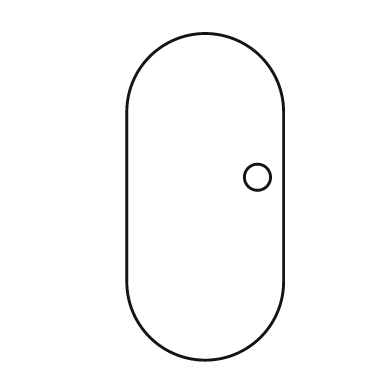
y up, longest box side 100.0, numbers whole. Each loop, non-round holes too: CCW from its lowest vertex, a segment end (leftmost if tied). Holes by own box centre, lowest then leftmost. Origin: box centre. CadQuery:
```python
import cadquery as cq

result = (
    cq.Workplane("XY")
    .moveTo(-24.0, -26.0)
    .threePointArc((0.0, -50.0), (24.0, -26.0))
    .lineTo(24.0, 26.0)
    .threePointArc((0.0, 50.0), (-24.0, 26.0))
    .close()
    .moveTo(16.0, 6.0)
    .circle(4.0)
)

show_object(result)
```